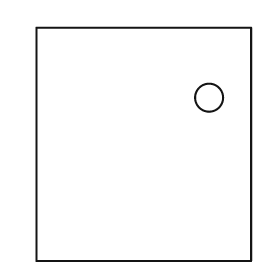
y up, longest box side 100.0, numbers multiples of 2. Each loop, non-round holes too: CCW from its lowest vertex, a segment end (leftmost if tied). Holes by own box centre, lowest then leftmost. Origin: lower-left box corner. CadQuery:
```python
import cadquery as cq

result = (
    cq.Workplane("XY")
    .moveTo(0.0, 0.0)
    .lineTo(92.0, 0.0)
    .lineTo(92.0, 100.0)
    .lineTo(0.0, 100.0)
    .close()
    .moveTo(74.0, 70.0)
    .circle(6.0)
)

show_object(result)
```